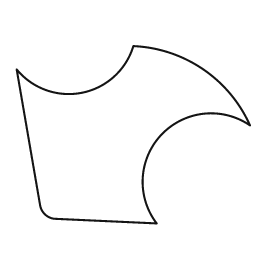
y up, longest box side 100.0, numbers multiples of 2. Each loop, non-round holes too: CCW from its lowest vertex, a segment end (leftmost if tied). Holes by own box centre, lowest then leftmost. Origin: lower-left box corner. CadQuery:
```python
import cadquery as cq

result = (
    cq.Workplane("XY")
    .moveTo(60.0, 0.0)
    .threePointArc((62.0, 38.0), (100.0, 42.0))
    .threePointArc((80.0, 66.0), (50.0, 76.0))
    .threePointArc((28.0, 56.0), (0.0, 66.0))
    .lineTo(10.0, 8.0)
    .threePointArc((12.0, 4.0), (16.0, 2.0))
    .close()
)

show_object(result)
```